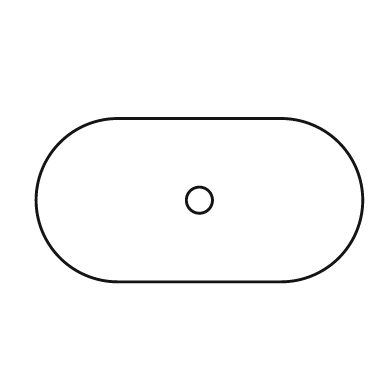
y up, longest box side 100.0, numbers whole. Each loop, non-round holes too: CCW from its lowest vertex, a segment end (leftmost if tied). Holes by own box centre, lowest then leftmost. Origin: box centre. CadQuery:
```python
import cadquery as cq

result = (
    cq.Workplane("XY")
    .moveTo(-25.0, -25.0)
    .lineTo(25.0, -25.0)
    .threePointArc((50.0, 0.0), (25.0, 25.0))
    .lineTo(-25.0, 25.0)
    .threePointArc((-50.0, 0.0), (-25.0, -25.0))
    .close()
    .moveTo(0.0, 0.0)
    .circle(4.0)
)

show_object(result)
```